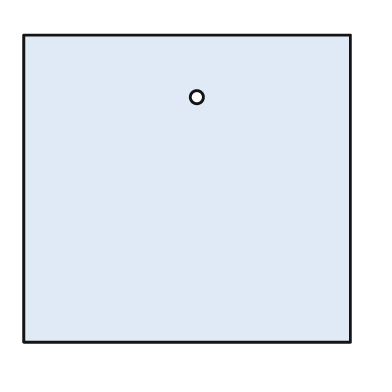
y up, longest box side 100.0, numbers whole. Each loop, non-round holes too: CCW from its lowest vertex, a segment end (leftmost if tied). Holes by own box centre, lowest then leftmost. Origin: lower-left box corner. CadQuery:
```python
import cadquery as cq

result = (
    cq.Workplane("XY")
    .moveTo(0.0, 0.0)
    .lineTo(100.0, 0.0)
    .lineTo(100.0, 94.0)
    .lineTo(0.0, 94.0)
    .close()
    .moveTo(53.0, 75.0)
    .circle(2.0)
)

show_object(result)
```